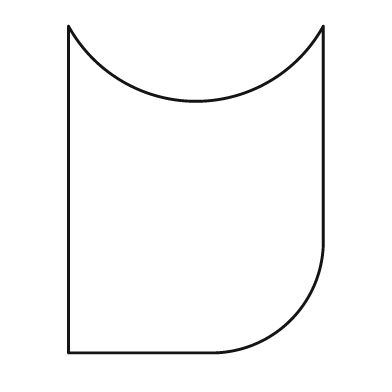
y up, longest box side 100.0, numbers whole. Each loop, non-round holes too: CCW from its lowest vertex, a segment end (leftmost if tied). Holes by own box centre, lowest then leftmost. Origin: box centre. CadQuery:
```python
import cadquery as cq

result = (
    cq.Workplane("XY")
    .moveTo(-39.0, -50.0)
    .lineTo(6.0, -50.0)
    .threePointArc((29.0, -40.0), (39.0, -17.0))
    .lineTo(39.0, 50.0)
    .threePointArc((0.0, 27.0), (-39.0, 50.0))
    .close()
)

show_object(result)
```